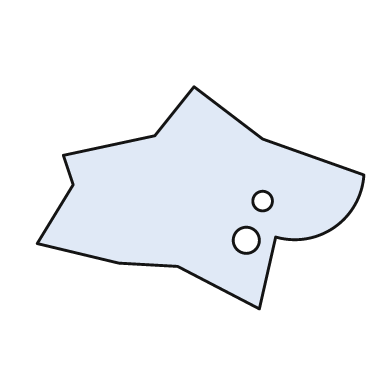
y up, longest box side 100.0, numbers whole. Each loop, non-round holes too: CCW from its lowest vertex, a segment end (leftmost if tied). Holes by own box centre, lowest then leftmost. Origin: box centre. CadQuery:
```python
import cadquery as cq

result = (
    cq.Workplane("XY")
    .moveTo(18.0, -34.0)
    .lineTo(23.0, -12.0)
    .threePointArc((41.0, -9.0), (50.0, 7.0))
    .lineTo(19.0, 18.0)
    .lineTo(-2.0, 34.0)
    .lineTo(-14.0, 19.0)
    .lineTo(-42.0, 13.0)
    .lineTo(-39.0, 4.0)
    .lineTo(-50.0, -14.0)
    .lineTo(-25.0, -20.0)
    .lineTo(-7.0, -21.0)
    .close()
    .moveTo(14.0, -13.0)
    .circle(4.0)
    .moveTo(19.0, -1.0)
    .circle(3.0)
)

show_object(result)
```